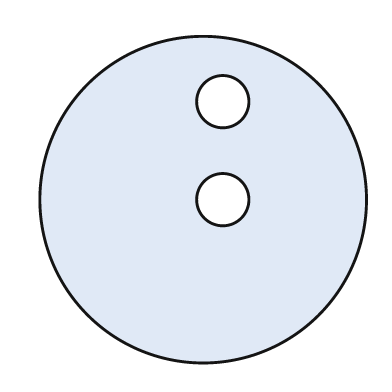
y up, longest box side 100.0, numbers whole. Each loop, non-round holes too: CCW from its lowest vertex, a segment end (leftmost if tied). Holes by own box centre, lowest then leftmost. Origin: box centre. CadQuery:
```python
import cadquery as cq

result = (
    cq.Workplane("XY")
    .moveTo(0.0, 0.0)
    .circle(50.0)
    .moveTo(6.0, 0.0)
    .circle(8.0)
    .moveTo(6.0, 30.0)
    .circle(8.0)
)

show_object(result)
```